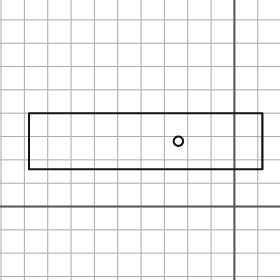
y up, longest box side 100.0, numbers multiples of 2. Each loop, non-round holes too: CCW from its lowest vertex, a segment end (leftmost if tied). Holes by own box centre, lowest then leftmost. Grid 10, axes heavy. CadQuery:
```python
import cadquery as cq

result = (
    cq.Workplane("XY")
    .moveTo(-88.0, 16.0)
    .lineTo(12.0, 16.0)
    .lineTo(12.0, 40.0)
    .lineTo(-88.0, 40.0)
    .close()
    .moveTo(-24.0, 28.0)
    .circle(2.0)
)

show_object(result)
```